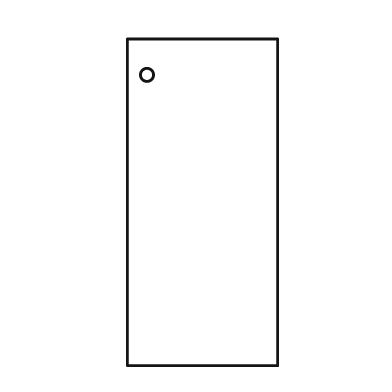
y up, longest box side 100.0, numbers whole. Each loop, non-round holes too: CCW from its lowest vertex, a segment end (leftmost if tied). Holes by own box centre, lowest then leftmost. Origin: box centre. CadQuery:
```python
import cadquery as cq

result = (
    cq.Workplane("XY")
    .moveTo(-23.0, -50.0)
    .lineTo(23.0, -50.0)
    .lineTo(23.0, 50.0)
    .lineTo(-23.0, 50.0)
    .close()
    .moveTo(-17.0, 39.0)
    .circle(2.0)
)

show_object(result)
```